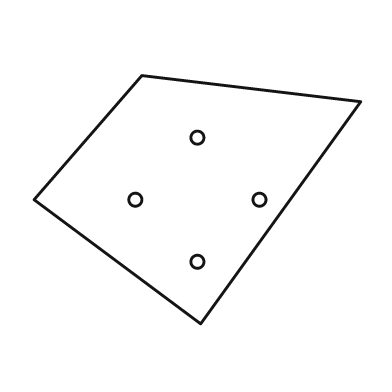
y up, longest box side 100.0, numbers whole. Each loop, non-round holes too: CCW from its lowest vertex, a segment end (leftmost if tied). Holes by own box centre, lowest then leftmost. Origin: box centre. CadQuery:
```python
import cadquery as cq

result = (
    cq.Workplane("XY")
    .moveTo(1.0, -38.0)
    .lineTo(50.0, 30.0)
    .lineTo(-17.0, 38.0)
    .lineTo(-50.0, 0.0)
    .close()
    .moveTo(0.0, -19.0)
    .circle(2.0)
    .moveTo(-19.0, 0.0)
    .circle(2.0)
    .moveTo(19.0, 0.0)
    .circle(2.0)
    .moveTo(0.0, 19.0)
    .circle(2.0)
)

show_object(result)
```